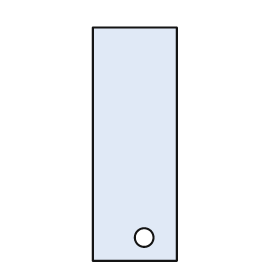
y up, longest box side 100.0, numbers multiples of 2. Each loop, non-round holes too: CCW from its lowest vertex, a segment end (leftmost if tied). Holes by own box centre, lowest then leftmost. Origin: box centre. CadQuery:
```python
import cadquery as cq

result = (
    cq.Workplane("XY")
    .moveTo(-18.0, -50.0)
    .lineTo(18.0, -50.0)
    .lineTo(18.0, 50.0)
    .lineTo(-18.0, 50.0)
    .close()
    .moveTo(4.0, -40.0)
    .circle(4.0)
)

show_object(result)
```